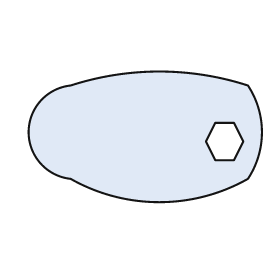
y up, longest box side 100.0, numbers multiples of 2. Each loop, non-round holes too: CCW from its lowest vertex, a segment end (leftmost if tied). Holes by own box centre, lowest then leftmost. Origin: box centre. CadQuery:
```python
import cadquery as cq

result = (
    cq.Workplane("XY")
    .moveTo(-32.0, -18.0)
    .threePointArc((6.0, -28.0), (44.0, -18.0))
    .threePointArc((50.0, 2.0), (44.0, 22.0))
    .threePointArc((6.0, 28.0), (-32.0, 22.0))
    .threePointArc((-50.0, 2.0), (-32.0, -18.0))
    .close()
    .moveTo(30.0, -10.0)
    .lineTo(38.0, -10.0)
    .lineTo(42.0, -2.0)
    .lineTo(38.0, 6.0)
    .lineTo(30.0, 6.0)
    .lineTo(26.0, -2.0)
    .close()
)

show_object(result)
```